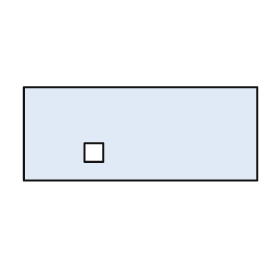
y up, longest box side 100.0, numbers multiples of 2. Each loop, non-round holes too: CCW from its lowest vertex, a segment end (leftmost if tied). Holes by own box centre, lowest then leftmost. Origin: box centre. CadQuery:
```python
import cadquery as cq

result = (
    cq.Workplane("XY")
    .moveTo(-50.0, -20.0)
    .lineTo(50.0, -20.0)
    .lineTo(50.0, 20.0)
    .lineTo(-50.0, 20.0)
    .close()
    .moveTo(-24.0, -12.0)
    .lineTo(-16.0, -12.0)
    .lineTo(-16.0, -4.0)
    .lineTo(-24.0, -4.0)
    .close()
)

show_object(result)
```